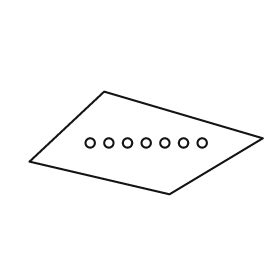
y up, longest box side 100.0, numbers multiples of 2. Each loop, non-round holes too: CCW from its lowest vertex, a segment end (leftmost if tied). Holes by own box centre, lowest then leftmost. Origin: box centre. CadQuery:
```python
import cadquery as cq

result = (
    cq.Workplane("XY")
    .moveTo(10.0, -22.0)
    .lineTo(50.0, 2.0)
    .lineTo(-18.0, 22.0)
    .lineTo(-50.0, -8.0)
    .close()
    .moveTo(-24.0, 0.0)
    .circle(2.0)
    .moveTo(-16.0, 0.0)
    .circle(2.0)
    .moveTo(-8.0, 0.0)
    .circle(2.0)
    .moveTo(0.0, 0.0)
    .circle(2.0)
    .moveTo(8.0, 0.0)
    .circle(2.0)
    .moveTo(16.0, 0.0)
    .circle(2.0)
    .moveTo(24.0, 0.0)
    .circle(2.0)
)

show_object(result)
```